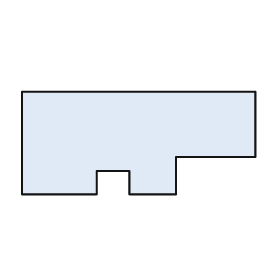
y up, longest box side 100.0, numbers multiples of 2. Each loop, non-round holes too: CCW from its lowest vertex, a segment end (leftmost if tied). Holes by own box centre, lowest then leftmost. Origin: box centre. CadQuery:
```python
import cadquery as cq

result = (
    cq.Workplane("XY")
    .moveTo(-50.0, -22.0)
    .lineTo(-18.0, -22.0)
    .lineTo(-18.0, -12.0)
    .lineTo(-4.0, -12.0)
    .lineTo(-4.0, -22.0)
    .lineTo(16.0, -22.0)
    .lineTo(16.0, -6.0)
    .lineTo(50.0, -6.0)
    .lineTo(50.0, 22.0)
    .lineTo(-50.0, 22.0)
    .close()
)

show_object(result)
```